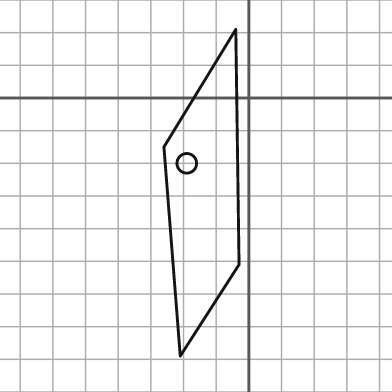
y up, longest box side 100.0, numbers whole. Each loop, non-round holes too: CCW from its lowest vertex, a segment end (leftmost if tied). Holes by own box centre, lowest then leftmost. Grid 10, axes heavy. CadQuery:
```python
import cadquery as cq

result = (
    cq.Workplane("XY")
    .moveTo(-21.0, -79.0)
    .lineTo(-3.0, -51.0)
    .lineTo(-4.0, 21.0)
    .lineTo(-26.0, -15.0)
    .close()
    .moveTo(-19.0, -20.0)
    .circle(3.0)
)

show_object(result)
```